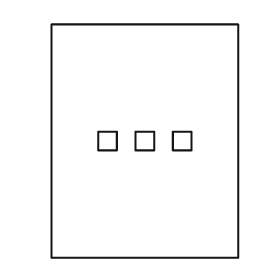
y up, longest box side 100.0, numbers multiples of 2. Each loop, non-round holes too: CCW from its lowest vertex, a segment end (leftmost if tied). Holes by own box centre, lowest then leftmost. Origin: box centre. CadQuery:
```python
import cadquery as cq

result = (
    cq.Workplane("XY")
    .moveTo(-40.0, -50.0)
    .lineTo(40.0, -50.0)
    .lineTo(40.0, 50.0)
    .lineTo(-40.0, 50.0)
    .close()
    .moveTo(-20.0, -4.0)
    .lineTo(-12.0, -4.0)
    .lineTo(-12.0, 4.0)
    .lineTo(-20.0, 4.0)
    .close()
    .moveTo(-4.0, -4.0)
    .lineTo(4.0, -4.0)
    .lineTo(4.0, 4.0)
    .lineTo(-4.0, 4.0)
    .close()
    .moveTo(12.0, -4.0)
    .lineTo(20.0, -4.0)
    .lineTo(20.0, 4.0)
    .lineTo(12.0, 4.0)
    .close()
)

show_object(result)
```